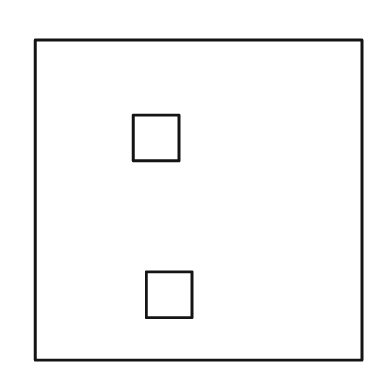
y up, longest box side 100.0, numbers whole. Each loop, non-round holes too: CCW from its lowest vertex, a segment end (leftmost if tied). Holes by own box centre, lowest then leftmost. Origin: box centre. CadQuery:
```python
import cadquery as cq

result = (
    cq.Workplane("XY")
    .moveTo(-50.0, -49.0)
    .lineTo(50.0, -49.0)
    .lineTo(50.0, 49.0)
    .lineTo(-50.0, 49.0)
    .close()
    .moveTo(-16.0, -36.0)
    .lineTo(-2.0, -36.0)
    .lineTo(-2.0, -22.0)
    .lineTo(-16.0, -22.0)
    .close()
    .moveTo(-20.0, 12.0)
    .lineTo(-6.0, 12.0)
    .lineTo(-6.0, 26.0)
    .lineTo(-20.0, 26.0)
    .close()
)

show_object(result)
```